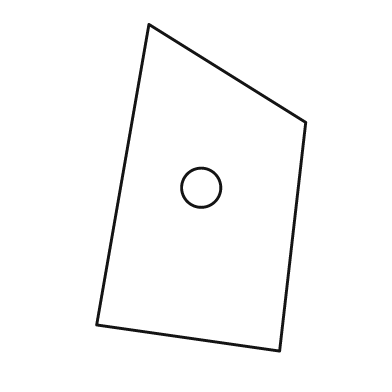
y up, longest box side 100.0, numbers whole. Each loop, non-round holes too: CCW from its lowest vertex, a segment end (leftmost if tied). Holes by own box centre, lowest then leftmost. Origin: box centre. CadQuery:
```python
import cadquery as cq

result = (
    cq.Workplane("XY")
    .moveTo(24.0, -50.0)
    .lineTo(32.0, 20.0)
    .lineTo(-16.0, 50.0)
    .lineTo(-32.0, -42.0)
    .close()
    .moveTo(0.0, 0.0)
    .circle(6.0)
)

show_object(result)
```